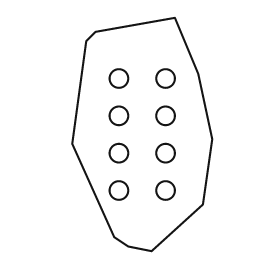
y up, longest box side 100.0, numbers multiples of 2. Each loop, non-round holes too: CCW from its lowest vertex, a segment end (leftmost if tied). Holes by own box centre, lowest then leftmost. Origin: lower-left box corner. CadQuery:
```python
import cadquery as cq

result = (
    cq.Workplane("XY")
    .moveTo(34.0, 0.0)
    .lineTo(56.0, 20.0)
    .lineTo(60.0, 48.0)
    .lineTo(54.0, 76.0)
    .lineTo(44.0, 100.0)
    .lineTo(10.0, 94.0)
    .lineTo(6.0, 90.0)
    .lineTo(0.0, 46.0)
    .lineTo(18.0, 6.0)
    .lineTo(24.0, 2.0)
    .close()
    .moveTo(20.0, 26.0)
    .circle(4.0)
    .moveTo(40.0, 26.0)
    .circle(4.0)
    .moveTo(20.0, 42.0)
    .circle(4.0)
    .moveTo(40.0, 42.0)
    .circle(4.0)
    .moveTo(20.0, 58.0)
    .circle(4.0)
    .moveTo(40.0, 58.0)
    .circle(4.0)
    .moveTo(20.0, 74.0)
    .circle(4.0)
    .moveTo(40.0, 74.0)
    .circle(4.0)
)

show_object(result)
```